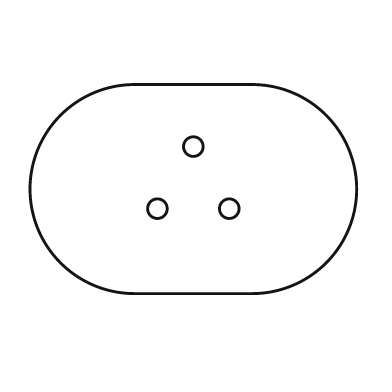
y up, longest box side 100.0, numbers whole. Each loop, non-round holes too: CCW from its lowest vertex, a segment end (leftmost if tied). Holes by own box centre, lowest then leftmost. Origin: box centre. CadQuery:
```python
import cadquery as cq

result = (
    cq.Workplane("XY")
    .moveTo(-18.0, -32.0)
    .lineTo(18.0, -32.0)
    .threePointArc((50.0, 0.0), (18.0, 32.0))
    .lineTo(-18.0, 32.0)
    .threePointArc((-50.0, 0.0), (-18.0, -32.0))
    .close()
    .moveTo(-11.0, -6.0)
    .circle(3.0)
    .moveTo(11.0, -6.0)
    .circle(3.0)
    .moveTo(0.0, 13.0)
    .circle(3.0)
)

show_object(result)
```